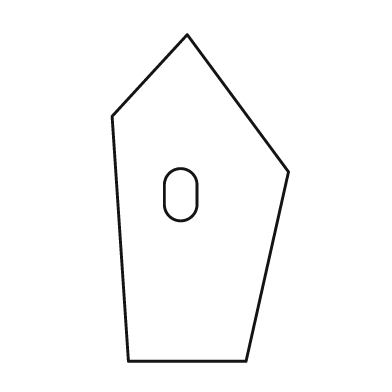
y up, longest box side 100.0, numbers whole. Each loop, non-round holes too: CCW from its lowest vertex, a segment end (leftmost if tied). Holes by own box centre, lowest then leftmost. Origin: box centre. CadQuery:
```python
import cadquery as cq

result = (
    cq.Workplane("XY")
    .moveTo(-22.0, -50.0)
    .lineTo(14.0, -50.0)
    .lineTo(27.0, 8.0)
    .lineTo(-4.0, 50.0)
    .lineTo(-27.0, 25.0)
    .close()
    .moveTo(-11.0, -2.0)
    .threePointArc((-6.0, -7.0), (-1.0, -2.0))
    .lineTo(-1.0, 4.0)
    .threePointArc((-6.0, 9.0), (-11.0, 4.0))
    .close()
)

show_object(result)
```